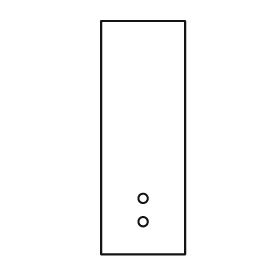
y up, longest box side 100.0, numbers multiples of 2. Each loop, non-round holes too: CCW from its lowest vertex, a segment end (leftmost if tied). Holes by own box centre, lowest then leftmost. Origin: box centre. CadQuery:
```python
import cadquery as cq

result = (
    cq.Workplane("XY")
    .moveTo(-18.0, -50.0)
    .lineTo(18.0, -50.0)
    .lineTo(18.0, 50.0)
    .lineTo(-18.0, 50.0)
    .close()
    .moveTo(0.0, -36.0)
    .circle(2.0)
    .moveTo(0.0, -26.0)
    .circle(2.0)
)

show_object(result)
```